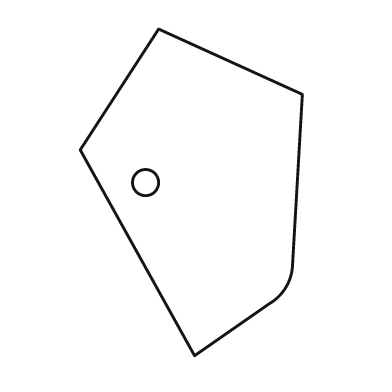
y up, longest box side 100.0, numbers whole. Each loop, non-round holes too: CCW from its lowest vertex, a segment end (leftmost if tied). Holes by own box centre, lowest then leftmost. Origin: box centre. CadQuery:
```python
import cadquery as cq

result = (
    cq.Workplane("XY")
    .moveTo(1.0, -50.0)
    .lineTo(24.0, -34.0)
    .threePointArc((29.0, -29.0), (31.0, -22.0))
    .lineTo(34.0, 30.0)
    .lineTo(-10.0, 50.0)
    .lineTo(-34.0, 13.0)
    .close()
    .moveTo(-14.0, 3.0)
    .circle(4.0)
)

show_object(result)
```